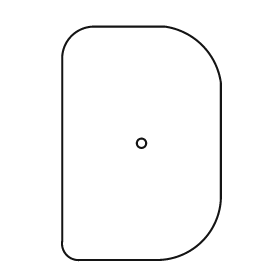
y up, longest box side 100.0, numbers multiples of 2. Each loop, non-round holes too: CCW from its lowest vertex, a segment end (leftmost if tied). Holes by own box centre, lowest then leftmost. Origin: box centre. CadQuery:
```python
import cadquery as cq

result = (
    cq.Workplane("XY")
    .moveTo(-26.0, -50.0)
    .lineTo(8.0, -50.0)
    .threePointArc((26.0, -42.0), (34.0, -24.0))
    .lineTo(34.0, 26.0)
    .threePointArc((26.0, 42.0), (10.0, 50.0))
    .lineTo(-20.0, 50.0)
    .threePointArc((-30.0, 46.0), (-34.0, 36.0))
    .lineTo(-34.0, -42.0)
    .threePointArc((-32.0, -48.0), (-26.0, -50.0))
    .close()
    .moveTo(0.0, 0.0)
    .circle(2.0)
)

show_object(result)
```